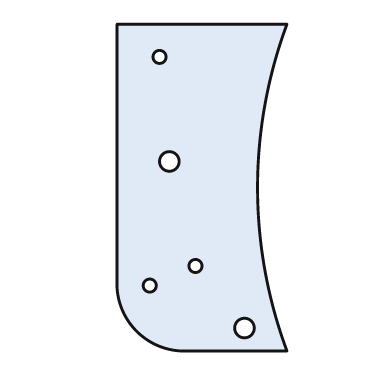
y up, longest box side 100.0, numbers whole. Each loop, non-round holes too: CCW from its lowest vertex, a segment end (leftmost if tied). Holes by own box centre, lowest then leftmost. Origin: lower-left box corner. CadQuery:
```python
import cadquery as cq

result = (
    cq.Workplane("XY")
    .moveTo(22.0, 0.0)
    .lineTo(52.0, 0.0)
    .threePointArc((43.0, 50.0), (52.0, 100.0))
    .lineTo(0.0, 100.0)
    .lineTo(0.0, 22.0)
    .threePointArc((6.0, 6.0), (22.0, 0.0))
    .close()
    .moveTo(39.0, 7.0)
    .circle(3.0)
    .moveTo(10.0, 20.0)
    .circle(2.0)
    .moveTo(24.0, 26.0)
    .circle(2.0)
    .moveTo(16.0, 58.0)
    .circle(3.0)
    .moveTo(13.0, 90.0)
    .circle(2.0)
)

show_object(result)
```